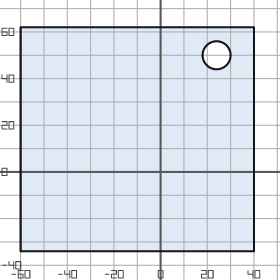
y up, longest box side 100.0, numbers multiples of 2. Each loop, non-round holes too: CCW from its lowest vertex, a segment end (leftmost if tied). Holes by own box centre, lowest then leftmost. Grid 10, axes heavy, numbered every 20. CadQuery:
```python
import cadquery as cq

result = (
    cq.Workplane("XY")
    .moveTo(-60.0, -34.0)
    .lineTo(40.0, -34.0)
    .lineTo(40.0, 62.0)
    .lineTo(-60.0, 62.0)
    .close()
    .moveTo(24.0, 50.0)
    .circle(6.0)
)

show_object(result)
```